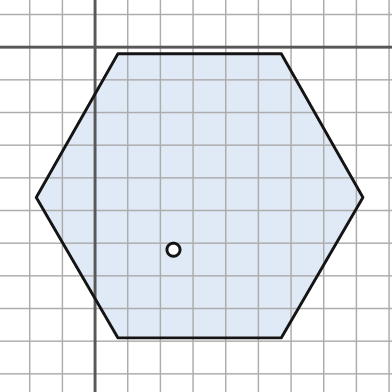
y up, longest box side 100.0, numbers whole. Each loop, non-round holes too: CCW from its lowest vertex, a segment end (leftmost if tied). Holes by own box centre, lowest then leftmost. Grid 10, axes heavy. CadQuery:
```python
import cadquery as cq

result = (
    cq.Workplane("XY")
    .moveTo(7.0, -89.0)
    .lineTo(57.0, -89.0)
    .lineTo(82.0, -46.0)
    .lineTo(57.0, -2.0)
    .lineTo(7.0, -2.0)
    .lineTo(-18.0, -46.0)
    .close()
    .moveTo(24.0, -62.0)
    .circle(2.0)
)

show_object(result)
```